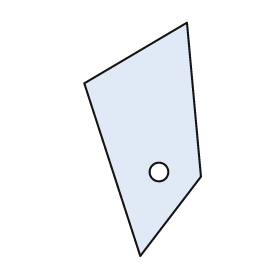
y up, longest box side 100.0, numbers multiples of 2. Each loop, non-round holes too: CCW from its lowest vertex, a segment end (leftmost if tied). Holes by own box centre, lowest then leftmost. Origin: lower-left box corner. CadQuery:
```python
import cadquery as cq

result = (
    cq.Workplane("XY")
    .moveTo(24.0, 0.0)
    .lineTo(50.0, 34.0)
    .lineTo(44.0, 100.0)
    .lineTo(0.0, 74.0)
    .close()
    .moveTo(32.0, 36.0)
    .circle(4.0)
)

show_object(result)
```